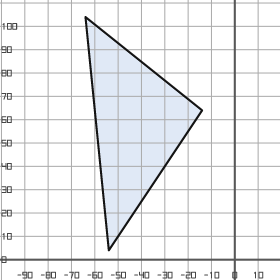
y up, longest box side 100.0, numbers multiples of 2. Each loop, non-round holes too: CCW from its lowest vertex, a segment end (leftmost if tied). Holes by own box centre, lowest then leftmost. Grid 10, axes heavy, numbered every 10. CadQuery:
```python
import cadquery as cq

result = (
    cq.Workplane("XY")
    .moveTo(-54.0, 4.0)
    .lineTo(-14.0, 64.0)
    .lineTo(-64.0, 104.0)
    .close()
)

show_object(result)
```